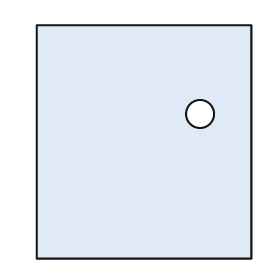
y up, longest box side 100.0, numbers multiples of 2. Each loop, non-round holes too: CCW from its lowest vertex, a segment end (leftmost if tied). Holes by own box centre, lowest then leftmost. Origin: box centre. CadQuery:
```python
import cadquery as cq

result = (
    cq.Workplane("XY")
    .moveTo(-46.0, -50.0)
    .lineTo(46.0, -50.0)
    .lineTo(46.0, 50.0)
    .lineTo(-46.0, 50.0)
    .close()
    .moveTo(24.0, 12.0)
    .circle(6.0)
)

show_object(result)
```